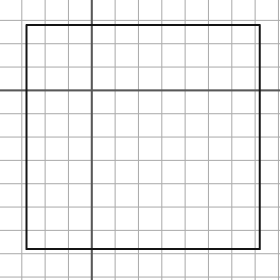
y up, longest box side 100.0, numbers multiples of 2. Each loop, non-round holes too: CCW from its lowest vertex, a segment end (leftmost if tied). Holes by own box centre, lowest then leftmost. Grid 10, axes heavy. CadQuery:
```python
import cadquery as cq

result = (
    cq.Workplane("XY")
    .moveTo(-28.0, -68.0)
    .lineTo(72.0, -68.0)
    .lineTo(72.0, 28.0)
    .lineTo(-28.0, 28.0)
    .close()
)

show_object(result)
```